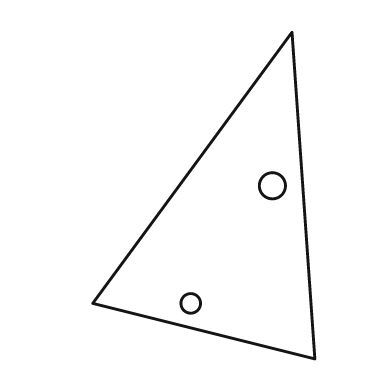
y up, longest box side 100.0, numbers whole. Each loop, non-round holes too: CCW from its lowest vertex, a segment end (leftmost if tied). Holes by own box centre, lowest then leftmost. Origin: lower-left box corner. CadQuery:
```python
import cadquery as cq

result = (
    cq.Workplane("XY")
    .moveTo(68.0, 0.0)
    .lineTo(61.0, 100.0)
    .lineTo(0.0, 17.0)
    .close()
    .moveTo(30.0, 17.0)
    .circle(3.0)
    .moveTo(55.0, 53.0)
    .circle(4.0)
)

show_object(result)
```